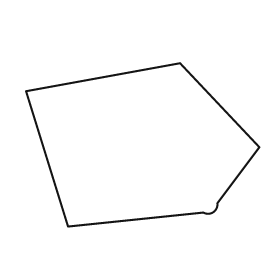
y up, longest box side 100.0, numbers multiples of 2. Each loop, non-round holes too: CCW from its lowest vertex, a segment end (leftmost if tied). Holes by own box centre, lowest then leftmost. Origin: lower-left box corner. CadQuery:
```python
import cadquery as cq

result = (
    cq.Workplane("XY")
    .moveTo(18.0, 0.0)
    .lineTo(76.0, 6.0)
    .threePointArc((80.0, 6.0), (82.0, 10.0))
    .lineTo(100.0, 34.0)
    .lineTo(66.0, 70.0)
    .lineTo(0.0, 58.0)
    .close()
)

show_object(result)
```